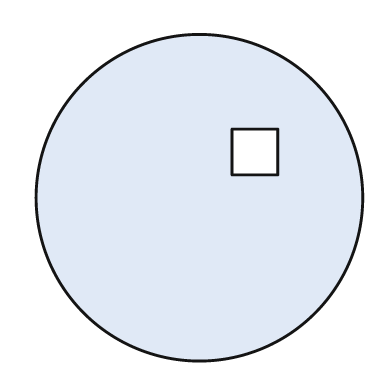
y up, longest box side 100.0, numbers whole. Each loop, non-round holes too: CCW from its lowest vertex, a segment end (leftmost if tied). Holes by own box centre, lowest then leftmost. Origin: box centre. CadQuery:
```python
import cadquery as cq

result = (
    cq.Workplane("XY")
    .moveTo(0.0, 0.0)
    .circle(50.0)
    .moveTo(10.0, 7.0)
    .lineTo(24.0, 7.0)
    .lineTo(24.0, 21.0)
    .lineTo(10.0, 21.0)
    .close()
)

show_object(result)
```